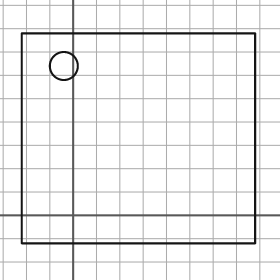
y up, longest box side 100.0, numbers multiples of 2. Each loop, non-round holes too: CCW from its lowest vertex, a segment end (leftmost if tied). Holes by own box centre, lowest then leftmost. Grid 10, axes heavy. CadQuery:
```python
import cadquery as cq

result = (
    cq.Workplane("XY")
    .moveTo(-22.0, -12.0)
    .lineTo(78.0, -12.0)
    .lineTo(78.0, 78.0)
    .lineTo(-22.0, 78.0)
    .close()
    .moveTo(-4.0, 64.0)
    .circle(6.0)
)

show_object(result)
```